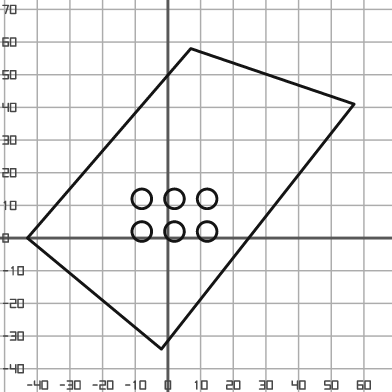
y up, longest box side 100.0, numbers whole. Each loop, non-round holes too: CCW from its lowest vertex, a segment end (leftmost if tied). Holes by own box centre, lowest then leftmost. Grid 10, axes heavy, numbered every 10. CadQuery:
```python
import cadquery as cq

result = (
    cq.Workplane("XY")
    .moveTo(-2.0, -34.0)
    .lineTo(57.0, 41.0)
    .lineTo(7.0, 58.0)
    .lineTo(-43.0, 0.0)
    .close()
    .moveTo(-8.0, 2.0)
    .circle(3.0)
    .moveTo(2.0, 2.0)
    .circle(3.0)
    .moveTo(12.0, 2.0)
    .circle(3.0)
    .moveTo(-8.0, 12.0)
    .circle(3.0)
    .moveTo(2.0, 12.0)
    .circle(3.0)
    .moveTo(12.0, 12.0)
    .circle(3.0)
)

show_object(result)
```